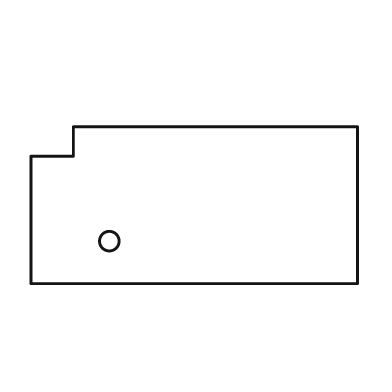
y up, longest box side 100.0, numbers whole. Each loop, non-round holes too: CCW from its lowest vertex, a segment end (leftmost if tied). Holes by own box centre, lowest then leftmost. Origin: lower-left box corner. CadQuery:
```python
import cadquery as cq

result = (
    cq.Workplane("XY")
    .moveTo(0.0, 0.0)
    .lineTo(100.0, 0.0)
    .lineTo(100.0, 48.0)
    .lineTo(13.0, 48.0)
    .lineTo(13.0, 39.0)
    .lineTo(0.0, 39.0)
    .close()
    .moveTo(24.0, 13.0)
    .circle(3.0)
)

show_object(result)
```